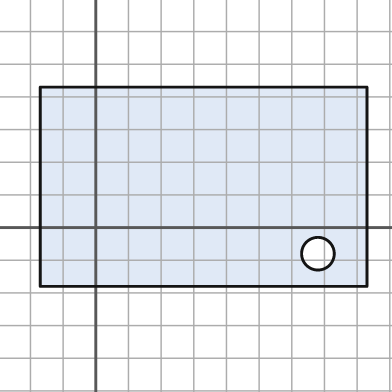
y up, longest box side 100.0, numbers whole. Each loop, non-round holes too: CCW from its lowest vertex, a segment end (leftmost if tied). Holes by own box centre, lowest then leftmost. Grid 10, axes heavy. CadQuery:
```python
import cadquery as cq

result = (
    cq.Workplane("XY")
    .moveTo(-17.0, -18.0)
    .lineTo(83.0, -18.0)
    .lineTo(83.0, 43.0)
    .lineTo(-17.0, 43.0)
    .close()
    .moveTo(68.0, -8.0)
    .circle(5.0)
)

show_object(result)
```